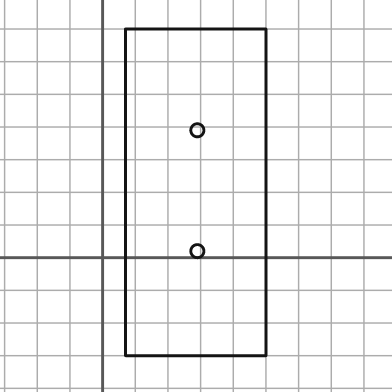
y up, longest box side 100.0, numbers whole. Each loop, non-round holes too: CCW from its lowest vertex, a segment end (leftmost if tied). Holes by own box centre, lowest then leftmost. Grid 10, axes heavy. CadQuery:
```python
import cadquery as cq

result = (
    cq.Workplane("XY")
    .moveTo(7.0, -30.0)
    .lineTo(50.0, -30.0)
    .lineTo(50.0, 70.0)
    .lineTo(7.0, 70.0)
    .close()
    .moveTo(29.0, 2.0)
    .circle(2.0)
    .moveTo(29.0, 39.0)
    .circle(2.0)
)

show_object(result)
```